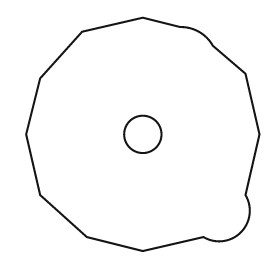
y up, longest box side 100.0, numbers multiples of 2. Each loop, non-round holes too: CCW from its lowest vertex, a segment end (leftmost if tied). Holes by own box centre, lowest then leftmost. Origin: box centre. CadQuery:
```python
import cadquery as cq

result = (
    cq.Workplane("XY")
    .moveTo(0.0, -50.0)
    .lineTo(26.0, -44.0)
    .threePointArc((42.0, -42.0), (44.0, -26.0))
    .lineTo(50.0, 0.0)
    .lineTo(44.0, 26.0)
    .lineTo(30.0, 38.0)
    .threePointArc((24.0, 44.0), (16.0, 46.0))
    .lineTo(0.0, 50.0)
    .lineTo(-26.0, 44.0)
    .lineTo(-44.0, 24.0)
    .lineTo(-50.0, 0.0)
    .lineTo(-44.0, -26.0)
    .lineTo(-24.0, -44.0)
    .close()
    .moveTo(0.0, 0.0)
    .circle(8.0)
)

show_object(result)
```